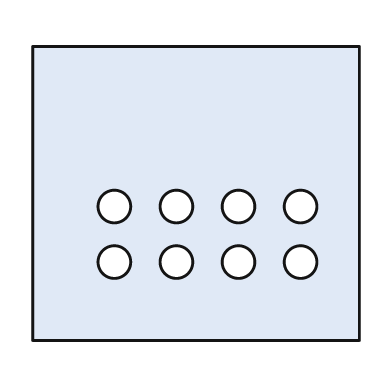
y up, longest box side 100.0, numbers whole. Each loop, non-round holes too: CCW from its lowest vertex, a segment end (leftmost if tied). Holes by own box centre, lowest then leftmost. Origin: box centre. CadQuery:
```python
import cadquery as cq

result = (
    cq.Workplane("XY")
    .moveTo(-50.0, -45.0)
    .lineTo(50.0, -45.0)
    .lineTo(50.0, 45.0)
    .lineTo(-50.0, 45.0)
    .close()
    .moveTo(-25.0, -21.0)
    .circle(5.0)
    .moveTo(-6.0, -21.0)
    .circle(5.0)
    .moveTo(13.0, -21.0)
    .circle(5.0)
    .moveTo(32.0, -21.0)
    .circle(5.0)
    .moveTo(-25.0, -4.0)
    .circle(5.0)
    .moveTo(-6.0, -4.0)
    .circle(5.0)
    .moveTo(13.0, -4.0)
    .circle(5.0)
    .moveTo(32.0, -4.0)
    .circle(5.0)
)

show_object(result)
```